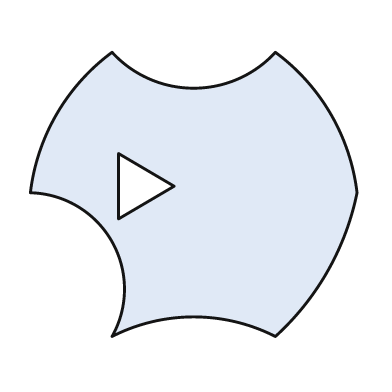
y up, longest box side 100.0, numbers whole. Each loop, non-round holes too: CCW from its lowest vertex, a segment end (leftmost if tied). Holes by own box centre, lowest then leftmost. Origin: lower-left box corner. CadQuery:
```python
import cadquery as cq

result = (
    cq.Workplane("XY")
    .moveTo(25.0, 0.0)
    .threePointArc((50.0, 6.0), (75.0, 0.0))
    .threePointArc((91.0, 20.0), (100.0, 44.0))
    .threePointArc((92.0, 68.0), (75.0, 87.0))
    .threePointArc((50.0, 76.0), (25.0, 87.0))
    .threePointArc((8.0, 68.0), (0.0, 44.0))
    .threePointArc((25.0, 29.0), (25.0, 0.0))
    .close()
    .moveTo(27.0, 36.0)
    .lineTo(44.0, 46.0)
    .lineTo(27.0, 56.0)
    .close()
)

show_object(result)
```